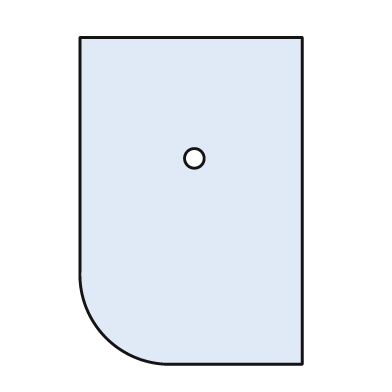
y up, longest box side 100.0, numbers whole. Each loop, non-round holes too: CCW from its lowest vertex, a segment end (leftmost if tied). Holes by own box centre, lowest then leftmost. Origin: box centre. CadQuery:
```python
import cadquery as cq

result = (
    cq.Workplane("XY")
    .moveTo(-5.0, -50.0)
    .lineTo(34.0, -50.0)
    .lineTo(34.0, 50.0)
    .lineTo(-34.0, 50.0)
    .lineTo(-34.0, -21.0)
    .threePointArc((-26.0, -42.0), (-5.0, -50.0))
    .close()
    .moveTo(1.0, 13.0)
    .circle(3.0)
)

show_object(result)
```